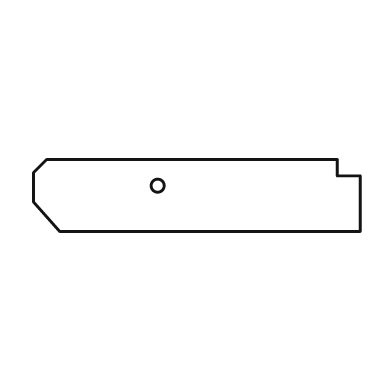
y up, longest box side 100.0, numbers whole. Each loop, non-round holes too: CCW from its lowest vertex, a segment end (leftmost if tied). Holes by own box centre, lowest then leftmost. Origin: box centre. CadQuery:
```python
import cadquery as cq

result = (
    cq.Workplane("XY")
    .moveTo(-42.0, -11.0)
    .lineTo(50.0, -11.0)
    .lineTo(50.0, 6.0)
    .lineTo(43.0, 6.0)
    .lineTo(43.0, 11.0)
    .lineTo(-46.0, 11.0)
    .lineTo(-50.0, 7.0)
    .lineTo(-50.0, -2.0)
    .close()
    .moveTo(-12.0, 3.0)
    .circle(2.0)
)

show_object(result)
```